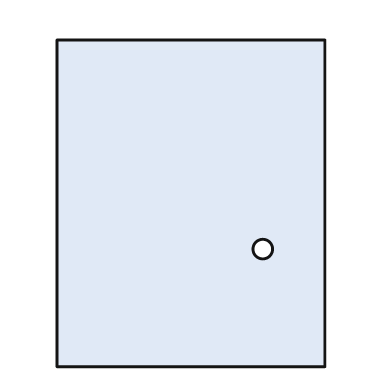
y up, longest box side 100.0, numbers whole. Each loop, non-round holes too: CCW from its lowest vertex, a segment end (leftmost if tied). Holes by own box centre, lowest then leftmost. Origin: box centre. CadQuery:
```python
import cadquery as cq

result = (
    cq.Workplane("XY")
    .moveTo(-41.0, -50.0)
    .lineTo(41.0, -50.0)
    .lineTo(41.0, 50.0)
    .lineTo(-41.0, 50.0)
    .close()
    .moveTo(22.0, -14.0)
    .circle(3.0)
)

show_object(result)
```